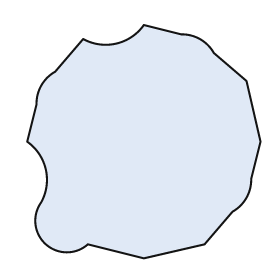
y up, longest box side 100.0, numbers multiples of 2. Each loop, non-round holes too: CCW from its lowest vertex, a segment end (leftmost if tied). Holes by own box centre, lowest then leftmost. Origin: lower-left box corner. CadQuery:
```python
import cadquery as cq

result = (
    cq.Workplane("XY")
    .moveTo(50.0, 0.0)
    .lineTo(76.0, 6.0)
    .lineTo(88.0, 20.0)
    .threePointArc((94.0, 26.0), (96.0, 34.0))
    .lineTo(100.0, 50.0)
    .lineTo(94.0, 76.0)
    .lineTo(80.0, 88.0)
    .threePointArc((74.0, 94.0), (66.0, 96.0))
    .lineTo(50.0, 100.0)
    .threePointArc((38.0, 92.0), (24.0, 94.0))
    .lineTo(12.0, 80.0)
    .threePointArc((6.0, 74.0), (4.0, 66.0))
    .lineTo(0.0, 50.0)
    .threePointArc((8.0, 38.0), (6.0, 24.0))
    .threePointArc((8.0, 6.0), (26.0, 6.0))
    .close()
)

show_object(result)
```